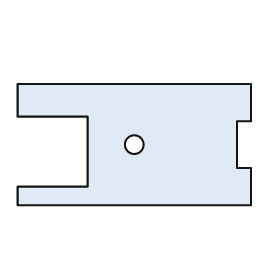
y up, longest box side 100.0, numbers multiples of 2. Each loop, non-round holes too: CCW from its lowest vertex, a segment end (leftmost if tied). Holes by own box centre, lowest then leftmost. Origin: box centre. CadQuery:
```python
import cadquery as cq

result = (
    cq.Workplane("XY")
    .moveTo(-50.0, -26.0)
    .lineTo(50.0, -26.0)
    .lineTo(50.0, -10.0)
    .lineTo(44.0, -10.0)
    .lineTo(44.0, 10.0)
    .lineTo(50.0, 10.0)
    .lineTo(50.0, 26.0)
    .lineTo(-50.0, 26.0)
    .lineTo(-50.0, 12.0)
    .lineTo(-20.0, 12.0)
    .lineTo(-20.0, -18.0)
    .lineTo(-50.0, -18.0)
    .close()
    .moveTo(0.0, 0.0)
    .circle(4.0)
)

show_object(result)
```